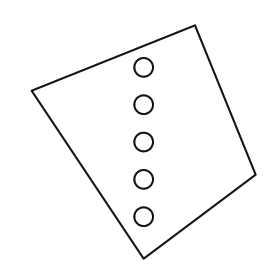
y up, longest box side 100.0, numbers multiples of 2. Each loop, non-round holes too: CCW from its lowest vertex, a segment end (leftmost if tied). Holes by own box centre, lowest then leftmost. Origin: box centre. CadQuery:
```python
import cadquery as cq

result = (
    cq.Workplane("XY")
    .moveTo(0.0, -50.0)
    .lineTo(48.0, -14.0)
    .lineTo(22.0, 50.0)
    .lineTo(-48.0, 22.0)
    .close()
    .moveTo(0.0, -32.0)
    .circle(4.0)
    .moveTo(0.0, -16.0)
    .circle(4.0)
    .moveTo(0.0, 0.0)
    .circle(4.0)
    .moveTo(0.0, 16.0)
    .circle(4.0)
    .moveTo(0.0, 32.0)
    .circle(4.0)
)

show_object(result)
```